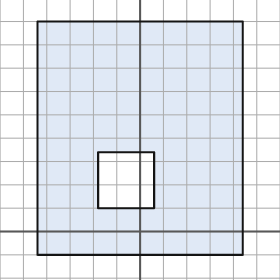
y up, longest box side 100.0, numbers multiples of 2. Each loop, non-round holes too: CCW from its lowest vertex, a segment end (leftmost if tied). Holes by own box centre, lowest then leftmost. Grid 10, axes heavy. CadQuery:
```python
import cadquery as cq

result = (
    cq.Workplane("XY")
    .moveTo(-44.0, -10.0)
    .lineTo(44.0, -10.0)
    .lineTo(44.0, 90.0)
    .lineTo(-44.0, 90.0)
    .close()
    .moveTo(-18.0, 10.0)
    .lineTo(6.0, 10.0)
    .lineTo(6.0, 34.0)
    .lineTo(-18.0, 34.0)
    .close()
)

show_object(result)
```